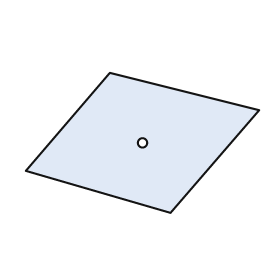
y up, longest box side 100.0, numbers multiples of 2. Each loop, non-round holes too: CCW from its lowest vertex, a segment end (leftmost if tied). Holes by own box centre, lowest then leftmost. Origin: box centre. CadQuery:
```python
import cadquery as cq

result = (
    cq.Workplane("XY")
    .moveTo(12.0, -30.0)
    .lineTo(50.0, 14.0)
    .lineTo(-14.0, 30.0)
    .lineTo(-50.0, -12.0)
    .close()
    .moveTo(0.0, 0.0)
    .circle(2.0)
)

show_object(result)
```